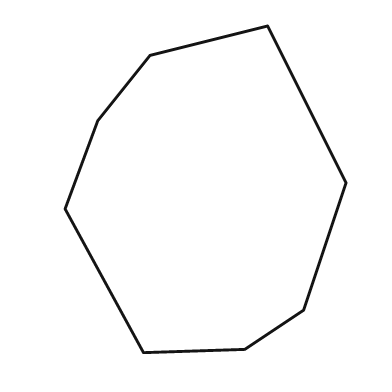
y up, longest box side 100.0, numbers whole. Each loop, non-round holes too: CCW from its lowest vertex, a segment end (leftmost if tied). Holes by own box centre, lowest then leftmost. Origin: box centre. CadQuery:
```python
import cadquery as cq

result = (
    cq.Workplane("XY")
    .moveTo(-19.0, -50.0)
    .lineTo(12.0, -49.0)
    .lineTo(30.0, -37.0)
    .lineTo(43.0, 2.0)
    .lineTo(19.0, 50.0)
    .lineTo(-17.0, 41.0)
    .lineTo(-33.0, 21.0)
    .lineTo(-43.0, -6.0)
    .close()
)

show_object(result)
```